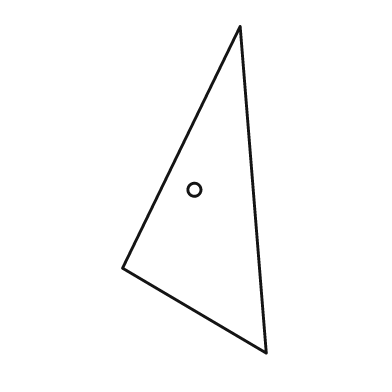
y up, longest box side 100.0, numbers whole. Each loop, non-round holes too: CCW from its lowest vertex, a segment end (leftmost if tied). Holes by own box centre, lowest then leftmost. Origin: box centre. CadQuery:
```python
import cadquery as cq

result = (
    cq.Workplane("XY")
    .moveTo(22.0, -50.0)
    .lineTo(14.0, 50.0)
    .lineTo(-22.0, -24.0)
    .close()
    .moveTo(0.0, 0.0)
    .circle(2.0)
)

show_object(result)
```